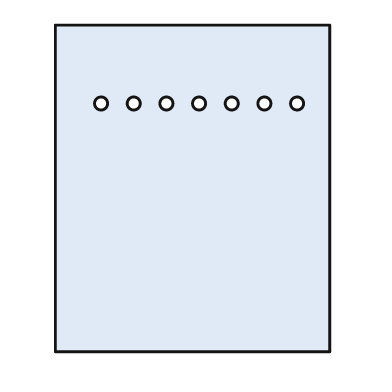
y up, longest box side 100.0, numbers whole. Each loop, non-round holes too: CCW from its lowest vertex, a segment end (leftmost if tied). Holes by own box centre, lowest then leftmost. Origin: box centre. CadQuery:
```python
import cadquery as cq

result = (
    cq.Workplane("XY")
    .moveTo(-42.0, -50.0)
    .lineTo(42.0, -50.0)
    .lineTo(42.0, 50.0)
    .lineTo(-42.0, 50.0)
    .close()
    .moveTo(-28.0, 26.0)
    .circle(2.0)
    .moveTo(-18.0, 26.0)
    .circle(2.0)
    .moveTo(-8.0, 26.0)
    .circle(2.0)
    .moveTo(2.0, 26.0)
    .circle(2.0)
    .moveTo(12.0, 26.0)
    .circle(2.0)
    .moveTo(22.0, 26.0)
    .circle(2.0)
    .moveTo(32.0, 26.0)
    .circle(2.0)
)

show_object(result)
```